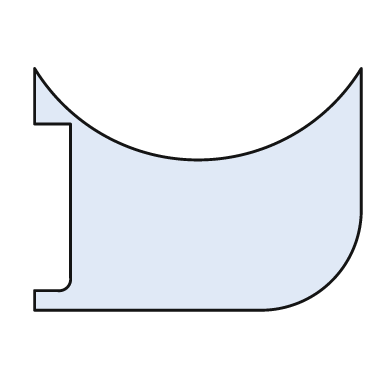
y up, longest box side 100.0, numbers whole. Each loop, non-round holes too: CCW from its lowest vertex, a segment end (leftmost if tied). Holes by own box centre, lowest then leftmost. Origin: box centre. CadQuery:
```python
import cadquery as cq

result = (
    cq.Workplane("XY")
    .moveTo(-50.0, -37.0)
    .lineTo(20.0, -37.0)
    .threePointArc((41.0, -28.0), (50.0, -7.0))
    .lineTo(50.0, 37.0)
    .threePointArc((0.0, 9.0), (-50.0, 37.0))
    .lineTo(-50.0, 20.0)
    .lineTo(-39.0, 20.0)
    .lineTo(-39.0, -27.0)
    .threePointArc((-40.0, -30.0), (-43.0, -31.0))
    .lineTo(-50.0, -31.0)
    .close()
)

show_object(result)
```